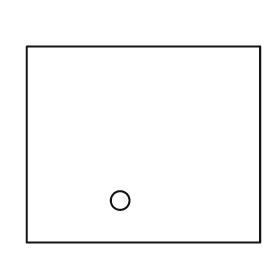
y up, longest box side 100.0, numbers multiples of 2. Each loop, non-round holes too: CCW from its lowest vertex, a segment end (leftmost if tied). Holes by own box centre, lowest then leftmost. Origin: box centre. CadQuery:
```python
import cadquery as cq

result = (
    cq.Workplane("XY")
    .moveTo(-50.0, -42.0)
    .lineTo(50.0, -42.0)
    .lineTo(50.0, 42.0)
    .lineTo(-50.0, 42.0)
    .close()
    .moveTo(-10.0, -24.0)
    .circle(4.0)
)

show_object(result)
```